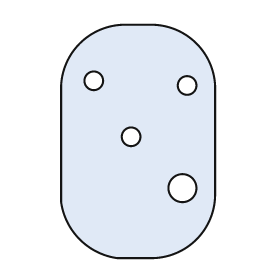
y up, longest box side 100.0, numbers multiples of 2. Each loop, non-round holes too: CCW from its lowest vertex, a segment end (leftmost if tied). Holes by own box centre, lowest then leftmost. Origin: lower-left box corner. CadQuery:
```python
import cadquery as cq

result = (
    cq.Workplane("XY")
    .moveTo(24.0, 0.0)
    .lineTo(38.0, 0.0)
    .threePointArc((58.0, 8.0), (66.0, 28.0))
    .lineTo(66.0, 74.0)
    .threePointArc((58.0, 92.0), (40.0, 100.0))
    .lineTo(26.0, 100.0)
    .threePointArc((8.0, 92.0), (0.0, 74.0))
    .lineTo(0.0, 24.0)
    .threePointArc((8.0, 8.0), (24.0, 0.0))
    .close()
    .moveTo(52.0, 30.0)
    .circle(6.0)
    .moveTo(30.0, 52.0)
    .circle(4.0)
    .moveTo(54.0, 74.0)
    .circle(4.0)
    .moveTo(14.0, 76.0)
    .circle(4.0)
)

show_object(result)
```